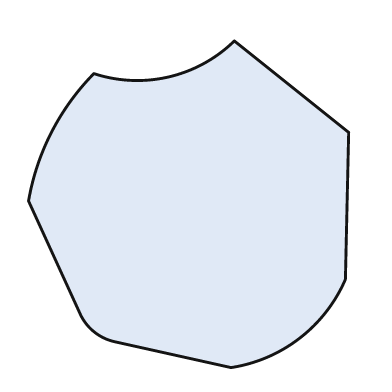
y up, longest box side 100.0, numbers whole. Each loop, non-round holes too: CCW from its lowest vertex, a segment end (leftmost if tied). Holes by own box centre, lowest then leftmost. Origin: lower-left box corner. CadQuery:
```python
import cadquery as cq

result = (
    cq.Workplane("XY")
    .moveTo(62.0, 0.0)
    .threePointArc((83.0, 9.0), (97.0, 27.0))
    .lineTo(98.0, 72.0)
    .lineTo(63.0, 100.0)
    .threePointArc((43.0, 89.0), (20.0, 90.0))
    .threePointArc((7.0, 72.0), (0.0, 51.0))
    .lineTo(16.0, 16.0)
    .threePointArc((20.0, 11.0), (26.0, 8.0))
    .close()
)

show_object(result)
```